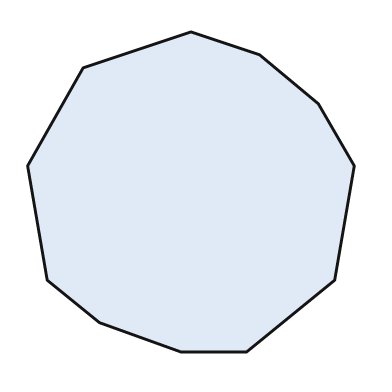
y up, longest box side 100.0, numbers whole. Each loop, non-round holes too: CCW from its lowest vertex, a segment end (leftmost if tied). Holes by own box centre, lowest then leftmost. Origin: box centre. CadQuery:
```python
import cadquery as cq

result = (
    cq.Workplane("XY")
    .moveTo(-3.0, -49.0)
    .lineTo(17.0, -49.0)
    .lineTo(44.0, -27.0)
    .lineTo(50.0, 8.0)
    .lineTo(39.0, 27.0)
    .lineTo(21.0, 42.0)
    .lineTo(0.0, 49.0)
    .lineTo(-33.0, 38.0)
    .lineTo(-50.0, 8.0)
    .lineTo(-44.0, -27.0)
    .lineTo(-28.0, -40.0)
    .close()
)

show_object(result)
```